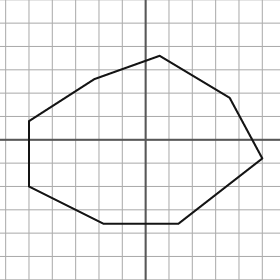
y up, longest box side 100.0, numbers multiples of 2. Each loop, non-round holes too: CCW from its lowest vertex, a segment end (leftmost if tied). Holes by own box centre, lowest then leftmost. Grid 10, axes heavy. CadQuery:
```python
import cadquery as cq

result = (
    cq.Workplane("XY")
    .moveTo(-18.0, -36.0)
    .lineTo(14.0, -36.0)
    .lineTo(50.0, -8.0)
    .lineTo(36.0, 18.0)
    .lineTo(6.0, 36.0)
    .lineTo(-22.0, 26.0)
    .lineTo(-50.0, 8.0)
    .lineTo(-50.0, -20.0)
    .close()
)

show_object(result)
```